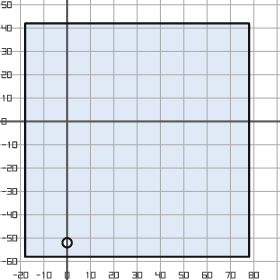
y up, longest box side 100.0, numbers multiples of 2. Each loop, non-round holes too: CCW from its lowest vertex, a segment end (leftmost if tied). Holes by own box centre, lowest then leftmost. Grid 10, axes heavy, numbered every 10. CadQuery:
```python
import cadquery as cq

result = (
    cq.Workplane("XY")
    .moveTo(-18.0, -58.0)
    .lineTo(78.0, -58.0)
    .lineTo(78.0, 42.0)
    .lineTo(-18.0, 42.0)
    .close()
    .moveTo(0.0, -52.0)
    .circle(2.0)
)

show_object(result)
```